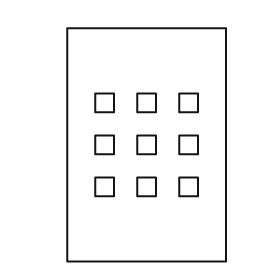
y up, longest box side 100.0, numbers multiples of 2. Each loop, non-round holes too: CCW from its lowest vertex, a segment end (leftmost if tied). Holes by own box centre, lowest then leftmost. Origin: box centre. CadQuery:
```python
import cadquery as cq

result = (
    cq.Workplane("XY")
    .moveTo(-34.0, -50.0)
    .lineTo(34.0, -50.0)
    .lineTo(34.0, 50.0)
    .lineTo(-34.0, 50.0)
    .close()
    .moveTo(-22.0, -22.0)
    .lineTo(-14.0, -22.0)
    .lineTo(-14.0, -14.0)
    .lineTo(-22.0, -14.0)
    .close()
    .moveTo(-4.0, -22.0)
    .lineTo(4.0, -22.0)
    .lineTo(4.0, -14.0)
    .lineTo(-4.0, -14.0)
    .close()
    .moveTo(14.0, -22.0)
    .lineTo(22.0, -22.0)
    .lineTo(22.0, -14.0)
    .lineTo(14.0, -14.0)
    .close()
    .moveTo(-22.0, -4.0)
    .lineTo(-14.0, -4.0)
    .lineTo(-14.0, 4.0)
    .lineTo(-22.0, 4.0)
    .close()
    .moveTo(-4.0, -4.0)
    .lineTo(4.0, -4.0)
    .lineTo(4.0, 4.0)
    .lineTo(-4.0, 4.0)
    .close()
    .moveTo(14.0, -4.0)
    .lineTo(22.0, -4.0)
    .lineTo(22.0, 4.0)
    .lineTo(14.0, 4.0)
    .close()
    .moveTo(-22.0, 14.0)
    .lineTo(-14.0, 14.0)
    .lineTo(-14.0, 22.0)
    .lineTo(-22.0, 22.0)
    .close()
    .moveTo(-4.0, 14.0)
    .lineTo(4.0, 14.0)
    .lineTo(4.0, 22.0)
    .lineTo(-4.0, 22.0)
    .close()
    .moveTo(14.0, 14.0)
    .lineTo(22.0, 14.0)
    .lineTo(22.0, 22.0)
    .lineTo(14.0, 22.0)
    .close()
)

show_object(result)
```